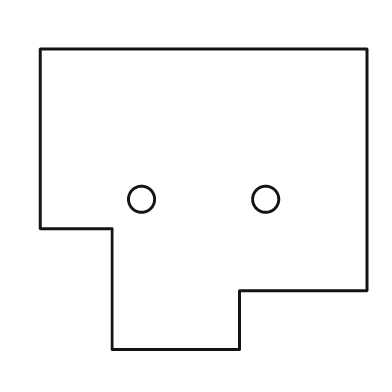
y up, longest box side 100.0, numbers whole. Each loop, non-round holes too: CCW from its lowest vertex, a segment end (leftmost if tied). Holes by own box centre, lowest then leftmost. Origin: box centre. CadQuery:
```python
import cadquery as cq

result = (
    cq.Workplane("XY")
    .moveTo(-28.0, -46.0)
    .lineTo(11.0, -46.0)
    .lineTo(11.0, -28.0)
    .lineTo(50.0, -28.0)
    .lineTo(50.0, 46.0)
    .lineTo(-50.0, 46.0)
    .lineTo(-50.0, -9.0)
    .lineTo(-28.0, -9.0)
    .close()
    .moveTo(-19.0, 0.0)
    .circle(4.0)
    .moveTo(19.0, 0.0)
    .circle(4.0)
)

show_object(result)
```